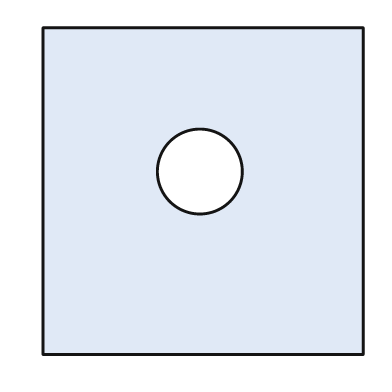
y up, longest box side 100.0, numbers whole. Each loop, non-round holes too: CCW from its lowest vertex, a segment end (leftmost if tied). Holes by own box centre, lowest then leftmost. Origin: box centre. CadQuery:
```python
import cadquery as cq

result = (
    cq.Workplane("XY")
    .moveTo(-49.0, -50.0)
    .lineTo(49.0, -50.0)
    .lineTo(49.0, 50.0)
    .lineTo(-49.0, 50.0)
    .close()
    .moveTo(-1.0, 6.0)
    .circle(13.0)
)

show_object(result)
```